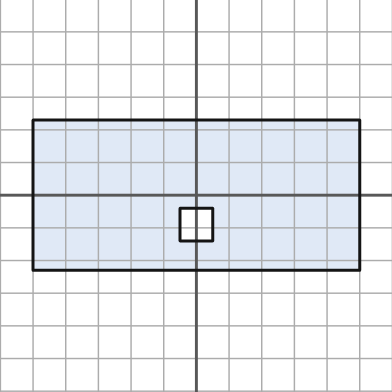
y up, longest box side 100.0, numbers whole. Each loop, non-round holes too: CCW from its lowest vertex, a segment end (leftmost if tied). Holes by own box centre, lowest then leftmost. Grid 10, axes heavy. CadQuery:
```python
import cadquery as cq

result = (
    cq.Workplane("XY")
    .moveTo(-50.0, -23.0)
    .lineTo(50.0, -23.0)
    .lineTo(50.0, 23.0)
    .lineTo(-50.0, 23.0)
    .close()
    .moveTo(-5.0, -14.0)
    .lineTo(5.0, -14.0)
    .lineTo(5.0, -4.0)
    .lineTo(-5.0, -4.0)
    .close()
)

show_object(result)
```